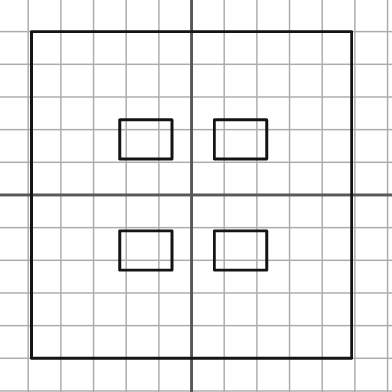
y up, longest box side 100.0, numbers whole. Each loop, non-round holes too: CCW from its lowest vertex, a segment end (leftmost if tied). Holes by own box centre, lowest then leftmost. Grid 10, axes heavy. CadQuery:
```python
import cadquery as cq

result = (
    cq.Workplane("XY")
    .moveTo(-49.0, -50.0)
    .lineTo(49.0, -50.0)
    .lineTo(49.0, 50.0)
    .lineTo(-49.0, 50.0)
    .close()
    .moveTo(-22.0, -23.0)
    .lineTo(-6.0, -23.0)
    .lineTo(-6.0, -11.0)
    .lineTo(-22.0, -11.0)
    .close()
    .moveTo(7.0, -23.0)
    .lineTo(23.0, -23.0)
    .lineTo(23.0, -11.0)
    .lineTo(7.0, -11.0)
    .close()
    .moveTo(-22.0, 11.0)
    .lineTo(-6.0, 11.0)
    .lineTo(-6.0, 23.0)
    .lineTo(-22.0, 23.0)
    .close()
    .moveTo(7.0, 11.0)
    .lineTo(23.0, 11.0)
    .lineTo(23.0, 23.0)
    .lineTo(7.0, 23.0)
    .close()
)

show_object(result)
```